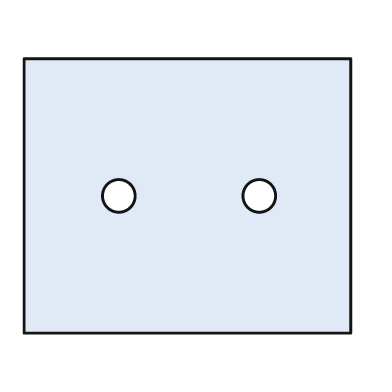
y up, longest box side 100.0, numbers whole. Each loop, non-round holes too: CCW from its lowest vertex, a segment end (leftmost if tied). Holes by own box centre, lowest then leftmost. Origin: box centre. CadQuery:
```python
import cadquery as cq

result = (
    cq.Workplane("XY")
    .moveTo(-50.0, -42.0)
    .lineTo(50.0, -42.0)
    .lineTo(50.0, 42.0)
    .lineTo(-50.0, 42.0)
    .close()
    .moveTo(-21.0, 0.0)
    .circle(5.0)
    .moveTo(22.0, 0.0)
    .circle(5.0)
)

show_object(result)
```